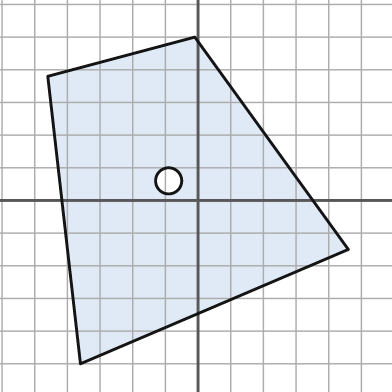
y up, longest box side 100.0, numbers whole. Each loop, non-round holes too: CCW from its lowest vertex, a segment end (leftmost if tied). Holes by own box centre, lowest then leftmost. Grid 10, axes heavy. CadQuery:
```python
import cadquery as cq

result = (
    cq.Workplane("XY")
    .moveTo(-36.0, -50.0)
    .lineTo(46.0, -15.0)
    .lineTo(-1.0, 50.0)
    .lineTo(-46.0, 38.0)
    .close()
    .moveTo(-9.0, 6.0)
    .circle(4.0)
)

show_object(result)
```